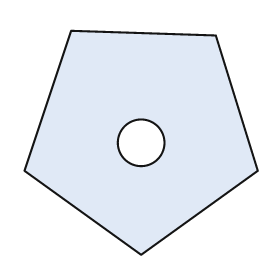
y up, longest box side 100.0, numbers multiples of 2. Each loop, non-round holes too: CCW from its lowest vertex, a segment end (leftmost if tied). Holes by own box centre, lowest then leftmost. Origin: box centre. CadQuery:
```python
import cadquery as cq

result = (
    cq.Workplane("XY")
    .moveTo(0.0, -48.0)
    .lineTo(50.0, -12.0)
    .lineTo(32.0, 46.0)
    .lineTo(-30.0, 48.0)
    .lineTo(-50.0, -12.0)
    .close()
    .moveTo(0.0, 0.0)
    .circle(10.0)
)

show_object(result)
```